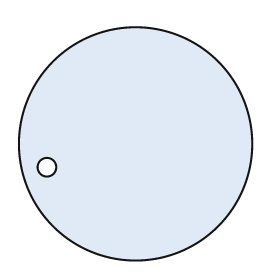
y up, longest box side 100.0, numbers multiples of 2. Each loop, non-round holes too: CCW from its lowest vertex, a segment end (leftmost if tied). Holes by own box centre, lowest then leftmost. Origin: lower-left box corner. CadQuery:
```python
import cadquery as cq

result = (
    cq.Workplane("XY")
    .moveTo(50.0, 50.0)
    .circle(50.0)
    .moveTo(12.0, 40.0)
    .circle(4.0)
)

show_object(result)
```